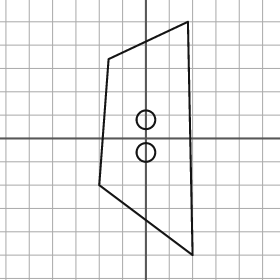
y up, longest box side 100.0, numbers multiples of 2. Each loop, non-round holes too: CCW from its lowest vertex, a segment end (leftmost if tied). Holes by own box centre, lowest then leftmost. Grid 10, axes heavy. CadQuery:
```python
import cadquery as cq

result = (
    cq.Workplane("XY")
    .moveTo(20.0, -50.0)
    .lineTo(18.0, 50.0)
    .lineTo(-16.0, 34.0)
    .lineTo(-20.0, -20.0)
    .close()
    .moveTo(0.0, -6.0)
    .circle(4.0)
    .moveTo(0.0, 8.0)
    .circle(4.0)
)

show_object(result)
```